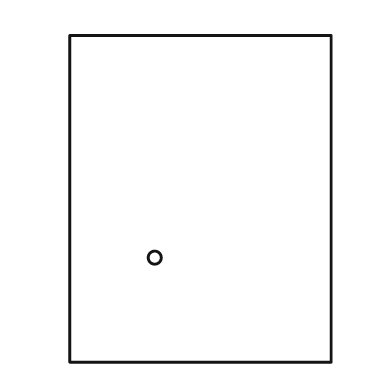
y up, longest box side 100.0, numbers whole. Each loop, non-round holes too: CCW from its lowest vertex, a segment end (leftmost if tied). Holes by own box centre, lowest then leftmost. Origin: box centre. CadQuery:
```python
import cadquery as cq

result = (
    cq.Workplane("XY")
    .moveTo(-40.0, -50.0)
    .lineTo(40.0, -50.0)
    .lineTo(40.0, 50.0)
    .lineTo(-40.0, 50.0)
    .close()
    .moveTo(-14.0, -18.0)
    .circle(2.0)
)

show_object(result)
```